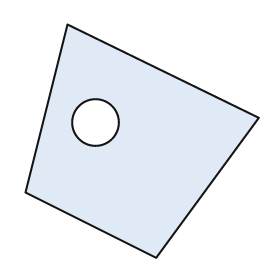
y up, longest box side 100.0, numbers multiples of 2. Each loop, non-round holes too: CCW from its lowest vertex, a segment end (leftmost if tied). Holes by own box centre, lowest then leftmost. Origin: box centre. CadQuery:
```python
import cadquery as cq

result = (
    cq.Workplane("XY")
    .moveTo(6.0, -50.0)
    .lineTo(50.0, 10.0)
    .lineTo(-32.0, 50.0)
    .lineTo(-50.0, -22.0)
    .close()
    .moveTo(-20.0, 8.0)
    .circle(10.0)
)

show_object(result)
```